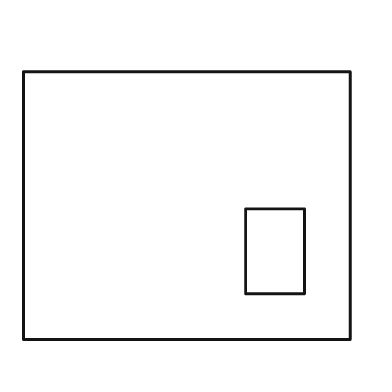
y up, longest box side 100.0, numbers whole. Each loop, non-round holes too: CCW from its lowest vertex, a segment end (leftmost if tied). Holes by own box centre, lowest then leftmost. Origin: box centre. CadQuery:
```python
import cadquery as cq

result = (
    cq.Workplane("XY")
    .moveTo(-50.0, -41.0)
    .lineTo(50.0, -41.0)
    .lineTo(50.0, 41.0)
    .lineTo(-50.0, 41.0)
    .close()
    .moveTo(18.0, -27.0)
    .lineTo(36.0, -27.0)
    .lineTo(36.0, -1.0)
    .lineTo(18.0, -1.0)
    .close()
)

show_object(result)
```